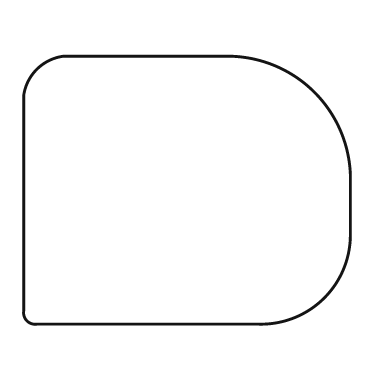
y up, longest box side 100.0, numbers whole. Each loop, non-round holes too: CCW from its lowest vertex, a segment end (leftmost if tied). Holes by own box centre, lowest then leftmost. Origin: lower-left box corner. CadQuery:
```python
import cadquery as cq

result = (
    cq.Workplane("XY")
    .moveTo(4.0, 0.0)
    .lineTo(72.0, 0.0)
    .threePointArc((92.0, 8.0), (100.0, 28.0))
    .lineTo(100.0, 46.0)
    .threePointArc((89.0, 71.0), (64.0, 82.0))
    .lineTo(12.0, 82.0)
    .threePointArc((4.0, 78.0), (0.0, 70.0))
    .lineTo(0.0, 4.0)
    .threePointArc((1.0, 1.0), (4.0, 0.0))
    .close()
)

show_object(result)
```